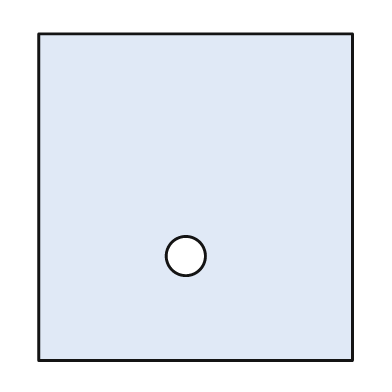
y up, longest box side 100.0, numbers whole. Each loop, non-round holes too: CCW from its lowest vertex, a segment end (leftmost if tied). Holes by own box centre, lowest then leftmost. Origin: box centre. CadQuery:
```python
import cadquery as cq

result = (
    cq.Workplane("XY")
    .moveTo(-48.0, -50.0)
    .lineTo(48.0, -50.0)
    .lineTo(48.0, 50.0)
    .lineTo(-48.0, 50.0)
    .close()
    .moveTo(-3.0, -18.0)
    .circle(6.0)
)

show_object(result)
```